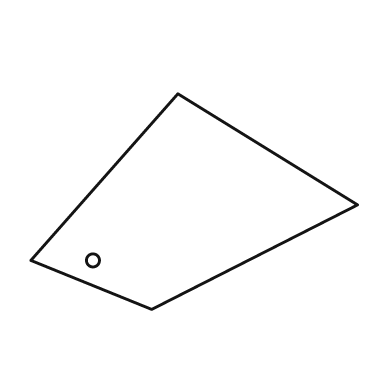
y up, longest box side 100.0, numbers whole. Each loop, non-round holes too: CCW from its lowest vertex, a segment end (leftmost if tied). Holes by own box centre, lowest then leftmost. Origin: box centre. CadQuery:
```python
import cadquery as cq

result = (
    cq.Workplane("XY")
    .moveTo(-13.0, -33.0)
    .lineTo(50.0, -1.0)
    .lineTo(-5.0, 33.0)
    .lineTo(-50.0, -18.0)
    .close()
    .moveTo(-31.0, -18.0)
    .circle(2.0)
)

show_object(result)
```